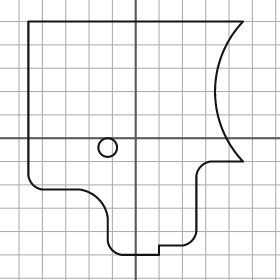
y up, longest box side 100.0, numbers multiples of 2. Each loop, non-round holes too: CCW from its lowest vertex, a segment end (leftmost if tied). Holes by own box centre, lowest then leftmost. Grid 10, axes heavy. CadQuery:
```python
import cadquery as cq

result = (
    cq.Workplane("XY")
    .moveTo(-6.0, -50.0)
    .lineTo(10.0, -50.0)
    .lineTo(10.0, -46.0)
    .lineTo(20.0, -46.0)
    .threePointArc((24.0, -44.0), (26.0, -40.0))
    .lineTo(26.0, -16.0)
    .threePointArc((28.0, -12.0), (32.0, -10.0))
    .lineTo(46.0, -10.0)
    .threePointArc((34.0, 20.0), (46.0, 50.0))
    .lineTo(-46.0, 50.0)
    .lineTo(-46.0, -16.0)
    .threePointArc((-44.0, -20.0), (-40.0, -22.0))
    .lineTo(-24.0, -22.0)
    .threePointArc((-16.0, -26.0), (-12.0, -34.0))
    .lineTo(-12.0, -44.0)
    .threePointArc((-10.0, -48.0), (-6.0, -50.0))
    .close()
    .moveTo(-12.0, -4.0)
    .circle(4.0)
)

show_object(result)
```